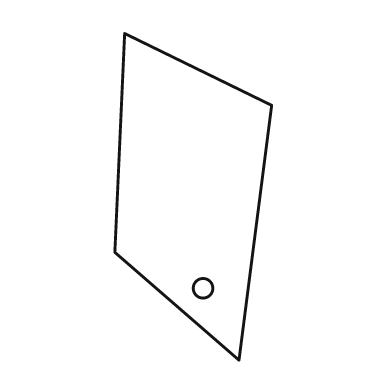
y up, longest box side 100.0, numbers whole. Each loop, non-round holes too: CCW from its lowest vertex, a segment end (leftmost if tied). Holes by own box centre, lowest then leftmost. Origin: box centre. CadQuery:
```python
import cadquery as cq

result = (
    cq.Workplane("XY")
    .moveTo(14.0, -50.0)
    .lineTo(24.0, 28.0)
    .lineTo(-21.0, 50.0)
    .lineTo(-24.0, -17.0)
    .close()
    .moveTo(3.0, -28.0)
    .circle(3.0)
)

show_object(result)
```